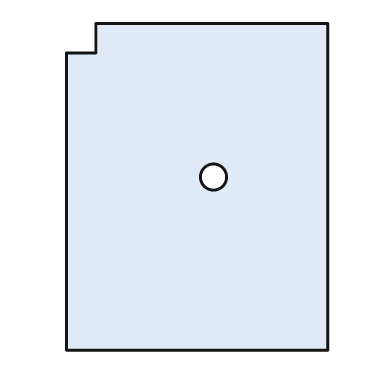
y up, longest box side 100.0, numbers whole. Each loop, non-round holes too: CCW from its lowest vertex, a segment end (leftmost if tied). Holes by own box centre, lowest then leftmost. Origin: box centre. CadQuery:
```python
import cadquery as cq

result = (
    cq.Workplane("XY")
    .moveTo(-40.0, -50.0)
    .lineTo(40.0, -50.0)
    .lineTo(40.0, 50.0)
    .lineTo(-31.0, 50.0)
    .lineTo(-31.0, 41.0)
    .lineTo(-40.0, 41.0)
    .close()
    .moveTo(5.0, 3.0)
    .circle(4.0)
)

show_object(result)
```